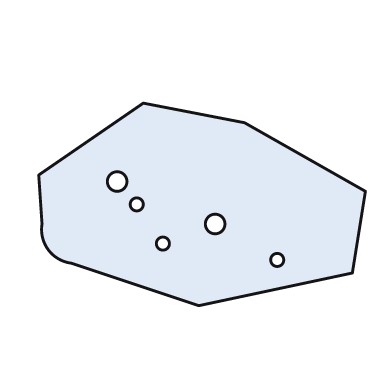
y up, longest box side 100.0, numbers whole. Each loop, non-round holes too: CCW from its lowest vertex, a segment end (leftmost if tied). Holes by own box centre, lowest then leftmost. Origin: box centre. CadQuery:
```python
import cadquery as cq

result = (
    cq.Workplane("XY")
    .moveTo(-1.0, -31.0)
    .lineTo(46.0, -21.0)
    .lineTo(50.0, 4.0)
    .lineTo(13.0, 25.0)
    .lineTo(-18.0, 31.0)
    .lineTo(-50.0, 9.0)
    .lineTo(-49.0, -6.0)
    .threePointArc((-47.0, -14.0), (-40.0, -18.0))
    .close()
    .moveTo(23.0, -17.0)
    .circle(2.0)
    .moveTo(-12.0, -12.0)
    .circle(2.0)
    .moveTo(4.0, -6.0)
    .circle(3.0)
    .moveTo(-20.0, 0.0)
    .circle(2.0)
    .moveTo(-26.0, 7.0)
    .circle(3.0)
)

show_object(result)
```